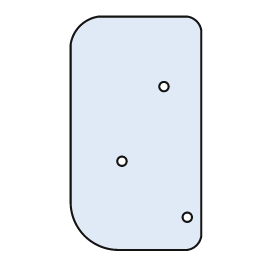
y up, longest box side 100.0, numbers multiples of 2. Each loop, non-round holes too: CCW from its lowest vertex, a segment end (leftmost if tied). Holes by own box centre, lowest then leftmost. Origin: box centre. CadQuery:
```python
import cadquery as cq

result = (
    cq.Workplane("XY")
    .moveTo(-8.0, -50.0)
    .lineTo(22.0, -50.0)
    .threePointArc((26.0, -48.0), (28.0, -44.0))
    .lineTo(28.0, 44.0)
    .threePointArc((26.0, 48.0), (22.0, 50.0))
    .lineTo(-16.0, 50.0)
    .threePointArc((-24.0, 46.0), (-28.0, 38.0))
    .lineTo(-28.0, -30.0)
    .threePointArc((-22.0, -44.0), (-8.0, -50.0))
    .close()
    .moveTo(22.0, -36.0)
    .circle(2.0)
    .moveTo(-6.0, -12.0)
    .circle(2.0)
    .moveTo(12.0, 20.0)
    .circle(2.0)
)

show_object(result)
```